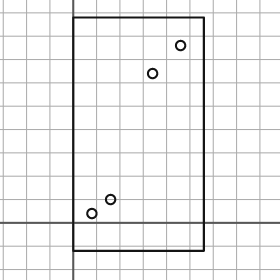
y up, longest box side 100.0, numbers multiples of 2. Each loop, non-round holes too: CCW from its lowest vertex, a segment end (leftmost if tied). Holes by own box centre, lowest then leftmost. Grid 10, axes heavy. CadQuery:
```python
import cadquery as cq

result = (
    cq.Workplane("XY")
    .moveTo(0.0, -12.0)
    .lineTo(56.0, -12.0)
    .lineTo(56.0, 88.0)
    .lineTo(0.0, 88.0)
    .close()
    .moveTo(8.0, 4.0)
    .circle(2.0)
    .moveTo(16.0, 10.0)
    .circle(2.0)
    .moveTo(34.0, 64.0)
    .circle(2.0)
    .moveTo(46.0, 76.0)
    .circle(2.0)
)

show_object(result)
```